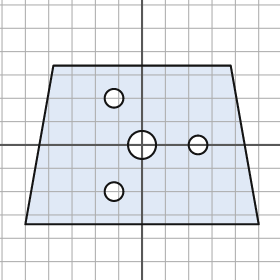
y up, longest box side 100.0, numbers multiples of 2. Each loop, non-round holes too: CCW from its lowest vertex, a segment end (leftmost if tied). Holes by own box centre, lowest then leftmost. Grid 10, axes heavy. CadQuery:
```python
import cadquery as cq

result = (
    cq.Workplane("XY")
    .moveTo(-50.0, -34.0)
    .lineTo(50.0, -34.0)
    .lineTo(38.0, 34.0)
    .lineTo(-38.0, 34.0)
    .close()
    .moveTo(-12.0, -20.0)
    .circle(4.0)
    .moveTo(0.0, 0.0)
    .circle(6.0)
    .moveTo(24.0, 0.0)
    .circle(4.0)
    .moveTo(-12.0, 20.0)
    .circle(4.0)
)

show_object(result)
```